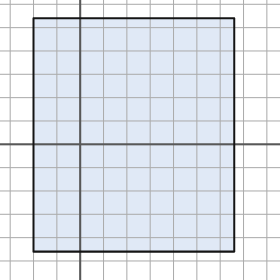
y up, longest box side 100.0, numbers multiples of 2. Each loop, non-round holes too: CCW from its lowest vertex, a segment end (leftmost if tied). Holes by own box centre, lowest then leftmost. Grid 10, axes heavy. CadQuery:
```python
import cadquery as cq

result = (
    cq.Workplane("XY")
    .moveTo(-20.0, -46.0)
    .lineTo(66.0, -46.0)
    .lineTo(66.0, 54.0)
    .lineTo(-20.0, 54.0)
    .close()
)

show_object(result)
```